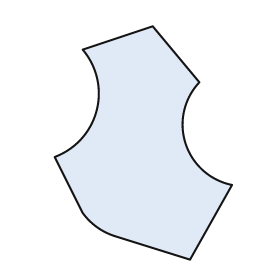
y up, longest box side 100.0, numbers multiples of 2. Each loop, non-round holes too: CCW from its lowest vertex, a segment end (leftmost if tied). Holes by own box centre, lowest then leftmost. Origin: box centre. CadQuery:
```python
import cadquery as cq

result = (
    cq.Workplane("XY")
    .moveTo(20.0, -50.0)
    .lineTo(38.0, -18.0)
    .threePointArc((18.0, 0.0), (24.0, 26.0))
    .lineTo(4.0, 50.0)
    .lineTo(-26.0, 40.0)
    .threePointArc((-20.0, 14.0), (-38.0, -6.0))
    .lineTo(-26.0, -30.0)
    .threePointArc((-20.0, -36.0), (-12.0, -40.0))
    .close()
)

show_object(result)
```